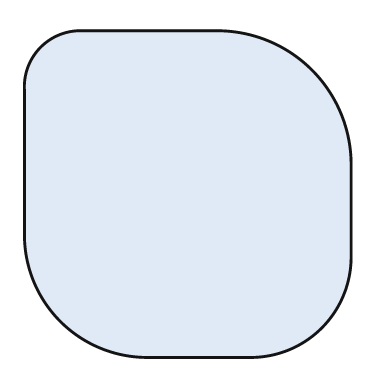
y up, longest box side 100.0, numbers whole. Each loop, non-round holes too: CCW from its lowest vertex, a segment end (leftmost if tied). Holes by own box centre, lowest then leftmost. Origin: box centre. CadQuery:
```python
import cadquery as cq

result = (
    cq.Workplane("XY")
    .moveTo(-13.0, -50.0)
    .lineTo(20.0, -50.0)
    .threePointArc((41.0, -41.0), (50.0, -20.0))
    .lineTo(50.0, 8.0)
    .threePointArc((38.0, 38.0), (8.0, 50.0))
    .lineTo(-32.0, 50.0)
    .threePointArc((-45.0, 45.0), (-50.0, 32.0))
    .lineTo(-50.0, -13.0)
    .threePointArc((-39.0, -39.0), (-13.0, -50.0))
    .close()
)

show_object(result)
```